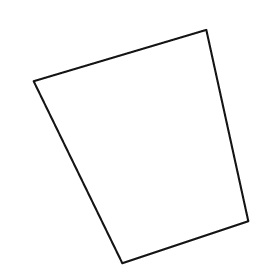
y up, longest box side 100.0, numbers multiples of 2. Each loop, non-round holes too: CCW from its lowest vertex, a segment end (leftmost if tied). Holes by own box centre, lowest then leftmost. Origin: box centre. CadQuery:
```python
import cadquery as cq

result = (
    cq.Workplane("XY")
    .moveTo(-8.0, -50.0)
    .lineTo(46.0, -32.0)
    .lineTo(28.0, 50.0)
    .lineTo(-46.0, 28.0)
    .close()
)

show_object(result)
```